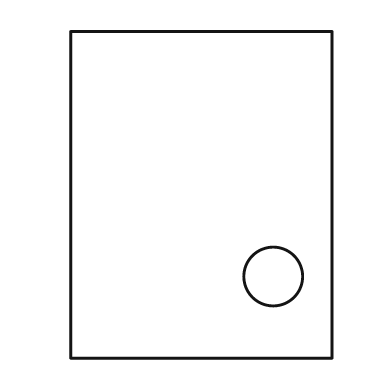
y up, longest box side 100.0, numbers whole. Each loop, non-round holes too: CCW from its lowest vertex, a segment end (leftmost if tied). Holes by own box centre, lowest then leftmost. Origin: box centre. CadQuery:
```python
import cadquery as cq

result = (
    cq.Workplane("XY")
    .moveTo(-40.0, -50.0)
    .lineTo(40.0, -50.0)
    .lineTo(40.0, 50.0)
    .lineTo(-40.0, 50.0)
    .close()
    .moveTo(22.0, -25.0)
    .circle(9.0)
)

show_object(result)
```